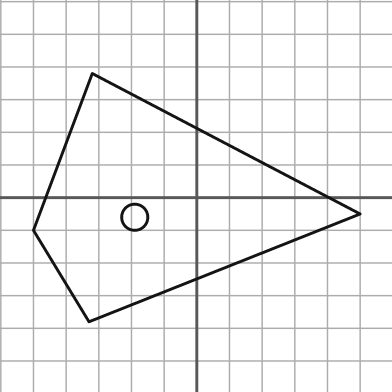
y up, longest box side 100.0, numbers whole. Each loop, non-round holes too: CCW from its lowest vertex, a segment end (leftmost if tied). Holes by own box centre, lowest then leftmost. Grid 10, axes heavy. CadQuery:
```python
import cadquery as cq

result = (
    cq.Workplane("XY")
    .moveTo(-33.0, -38.0)
    .lineTo(50.0, -5.0)
    .lineTo(-32.0, 38.0)
    .lineTo(-50.0, -10.0)
    .close()
    .moveTo(-19.0, -6.0)
    .circle(4.0)
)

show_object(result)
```